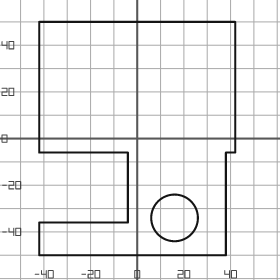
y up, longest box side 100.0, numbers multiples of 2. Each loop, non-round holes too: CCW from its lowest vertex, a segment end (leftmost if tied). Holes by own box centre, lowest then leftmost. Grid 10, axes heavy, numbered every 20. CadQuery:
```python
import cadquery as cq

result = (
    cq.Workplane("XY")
    .moveTo(-42.0, -50.0)
    .lineTo(38.0, -50.0)
    .lineTo(38.0, -6.0)
    .lineTo(42.0, -6.0)
    .lineTo(42.0, 50.0)
    .lineTo(-42.0, 50.0)
    .lineTo(-42.0, -6.0)
    .lineTo(-4.0, -6.0)
    .lineTo(-4.0, -36.0)
    .lineTo(-42.0, -36.0)
    .close()
    .moveTo(16.0, -34.0)
    .circle(10.0)
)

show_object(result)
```